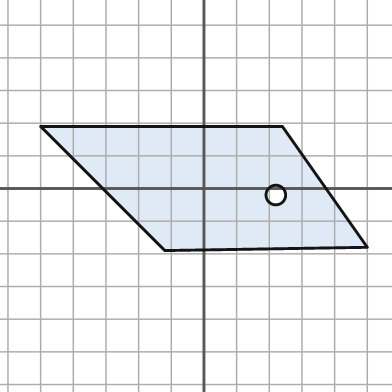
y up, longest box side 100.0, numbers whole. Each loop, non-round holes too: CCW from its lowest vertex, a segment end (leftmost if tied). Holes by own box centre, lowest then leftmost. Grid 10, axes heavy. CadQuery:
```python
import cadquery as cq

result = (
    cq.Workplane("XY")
    .moveTo(-12.0, -19.0)
    .lineTo(50.0, -18.0)
    .lineTo(24.0, 19.0)
    .lineTo(-50.0, 19.0)
    .close()
    .moveTo(22.0, -2.0)
    .circle(3.0)
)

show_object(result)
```